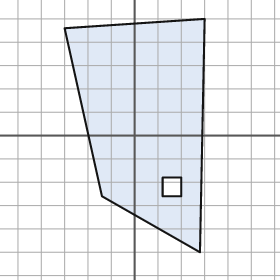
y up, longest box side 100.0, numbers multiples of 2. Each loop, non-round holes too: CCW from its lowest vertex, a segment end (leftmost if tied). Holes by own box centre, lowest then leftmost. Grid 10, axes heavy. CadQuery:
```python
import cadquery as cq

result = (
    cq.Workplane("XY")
    .moveTo(28.0, -50.0)
    .lineTo(30.0, 50.0)
    .lineTo(-30.0, 46.0)
    .lineTo(-14.0, -26.0)
    .close()
    .moveTo(12.0, -26.0)
    .lineTo(20.0, -26.0)
    .lineTo(20.0, -18.0)
    .lineTo(12.0, -18.0)
    .close()
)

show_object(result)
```